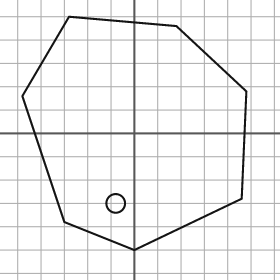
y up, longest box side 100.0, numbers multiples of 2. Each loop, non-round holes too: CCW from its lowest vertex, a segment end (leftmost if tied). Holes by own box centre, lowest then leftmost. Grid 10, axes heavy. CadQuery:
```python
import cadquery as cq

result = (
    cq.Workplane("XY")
    .moveTo(0.0, -50.0)
    .lineTo(46.0, -28.0)
    .lineTo(48.0, 18.0)
    .lineTo(18.0, 46.0)
    .lineTo(-28.0, 50.0)
    .lineTo(-48.0, 16.0)
    .lineTo(-30.0, -38.0)
    .close()
    .moveTo(-8.0, -30.0)
    .circle(4.0)
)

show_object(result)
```